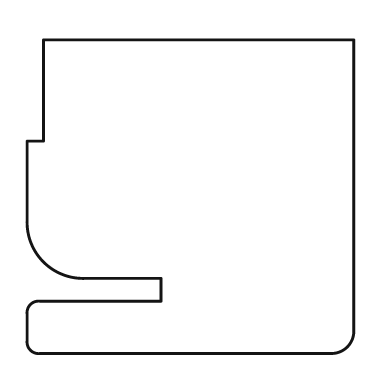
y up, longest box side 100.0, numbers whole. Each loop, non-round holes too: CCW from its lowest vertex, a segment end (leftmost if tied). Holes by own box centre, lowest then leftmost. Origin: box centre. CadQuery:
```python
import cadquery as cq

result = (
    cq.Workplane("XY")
    .moveTo(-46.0, -48.0)
    .lineTo(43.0, -48.0)
    .threePointArc((48.0, -46.0), (50.0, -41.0))
    .lineTo(50.0, 48.0)
    .lineTo(-45.0, 48.0)
    .lineTo(-45.0, 17.0)
    .lineTo(-50.0, 17.0)
    .lineTo(-50.0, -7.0)
    .threePointArc((-45.0, -20.0), (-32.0, -25.0))
    .lineTo(-9.0, -25.0)
    .lineTo(-9.0, -32.0)
    .lineTo(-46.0, -32.0)
    .threePointArc((-49.0, -33.0), (-50.0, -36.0))
    .lineTo(-50.0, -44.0)
    .threePointArc((-49.0, -47.0), (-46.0, -48.0))
    .close()
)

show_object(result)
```